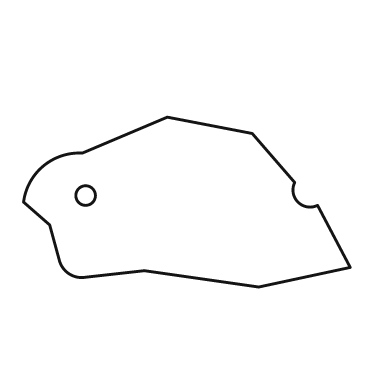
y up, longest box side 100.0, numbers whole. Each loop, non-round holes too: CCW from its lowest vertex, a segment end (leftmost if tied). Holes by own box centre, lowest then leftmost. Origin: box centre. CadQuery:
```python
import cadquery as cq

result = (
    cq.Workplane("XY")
    .moveTo(22.0, -26.0)
    .lineTo(50.0, -20.0)
    .lineTo(40.0, -1.0)
    .threePointArc((34.0, 0.0), (33.0, 6.0))
    .lineTo(20.0, 21.0)
    .lineTo(-6.0, 26.0)
    .lineTo(-32.0, 15.0)
    .threePointArc((-44.0, 11.0), (-50.0, 0.0))
    .lineTo(-42.0, -7.0)
    .lineTo(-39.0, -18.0)
    .threePointArc((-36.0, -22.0), (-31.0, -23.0))
    .lineTo(-13.0, -21.0)
    .close()
    .moveTo(-31.0, 2.0)
    .circle(3.0)
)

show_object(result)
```